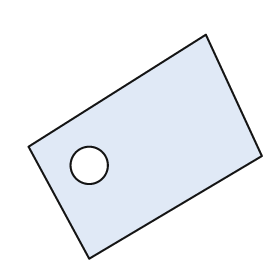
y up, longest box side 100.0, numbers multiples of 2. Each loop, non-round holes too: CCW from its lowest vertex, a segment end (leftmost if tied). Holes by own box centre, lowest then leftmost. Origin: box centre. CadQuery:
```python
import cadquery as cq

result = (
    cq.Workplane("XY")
    .moveTo(-24.0, -48.0)
    .lineTo(50.0, -4.0)
    .lineTo(26.0, 48.0)
    .lineTo(-50.0, 0.0)
    .close()
    .moveTo(-24.0, -8.0)
    .circle(8.0)
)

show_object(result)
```